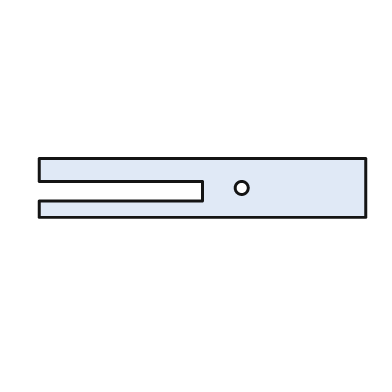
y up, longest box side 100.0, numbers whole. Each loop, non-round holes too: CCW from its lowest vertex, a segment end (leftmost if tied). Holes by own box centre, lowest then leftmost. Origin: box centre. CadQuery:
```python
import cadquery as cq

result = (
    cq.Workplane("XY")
    .moveTo(-50.0, -9.0)
    .lineTo(50.0, -9.0)
    .lineTo(50.0, 9.0)
    .lineTo(-50.0, 9.0)
    .lineTo(-50.0, 2.0)
    .lineTo(0.0, 2.0)
    .lineTo(0.0, -4.0)
    .lineTo(-50.0, -4.0)
    .close()
    .moveTo(12.0, 0.0)
    .circle(2.0)
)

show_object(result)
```